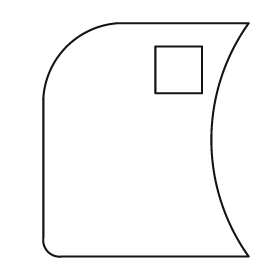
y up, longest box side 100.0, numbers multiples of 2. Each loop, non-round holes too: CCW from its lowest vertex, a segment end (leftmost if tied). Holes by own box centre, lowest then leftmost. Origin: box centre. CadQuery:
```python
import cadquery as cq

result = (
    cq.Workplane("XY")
    .moveTo(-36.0, -50.0)
    .lineTo(44.0, -50.0)
    .threePointArc((28.0, 0.0), (44.0, 50.0))
    .lineTo(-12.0, 50.0)
    .threePointArc((-34.0, 40.0), (-44.0, 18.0))
    .lineTo(-44.0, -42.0)
    .threePointArc((-42.0, -48.0), (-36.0, -50.0))
    .close()
    .moveTo(4.0, 20.0)
    .lineTo(24.0, 20.0)
    .lineTo(24.0, 40.0)
    .lineTo(4.0, 40.0)
    .close()
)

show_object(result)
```